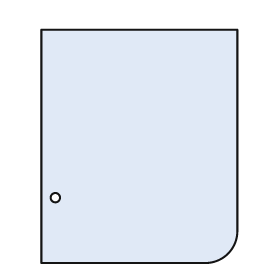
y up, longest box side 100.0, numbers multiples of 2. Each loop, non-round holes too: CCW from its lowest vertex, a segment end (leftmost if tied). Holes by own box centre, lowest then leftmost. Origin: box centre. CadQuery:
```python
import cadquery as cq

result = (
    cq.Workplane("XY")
    .moveTo(-42.0, -50.0)
    .lineTo(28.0, -50.0)
    .threePointArc((38.0, -46.0), (42.0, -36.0))
    .lineTo(42.0, 50.0)
    .lineTo(-42.0, 50.0)
    .close()
    .moveTo(-36.0, -22.0)
    .circle(2.0)
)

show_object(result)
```